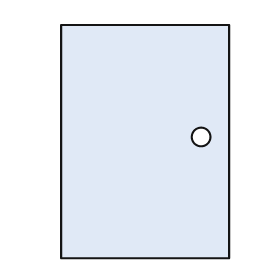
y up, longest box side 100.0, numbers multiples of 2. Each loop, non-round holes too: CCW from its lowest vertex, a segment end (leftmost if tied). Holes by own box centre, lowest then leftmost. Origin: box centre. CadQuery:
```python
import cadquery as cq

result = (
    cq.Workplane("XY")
    .moveTo(-36.0, -50.0)
    .lineTo(36.0, -50.0)
    .lineTo(36.0, 50.0)
    .lineTo(-36.0, 50.0)
    .close()
    .moveTo(24.0, 2.0)
    .circle(4.0)
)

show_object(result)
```